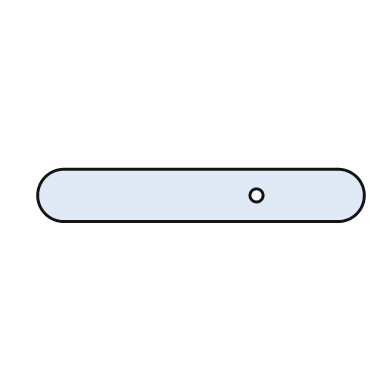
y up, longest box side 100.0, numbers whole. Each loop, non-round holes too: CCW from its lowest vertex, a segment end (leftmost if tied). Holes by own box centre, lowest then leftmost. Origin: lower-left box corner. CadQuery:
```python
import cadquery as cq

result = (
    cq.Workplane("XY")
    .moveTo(8.0, 0.0)
    .lineTo(92.0, 0.0)
    .threePointArc((100.0, 8.0), (92.0, 16.0))
    .lineTo(8.0, 16.0)
    .threePointArc((0.0, 8.0), (8.0, 0.0))
    .close()
    .moveTo(67.0, 8.0)
    .circle(2.0)
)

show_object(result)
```